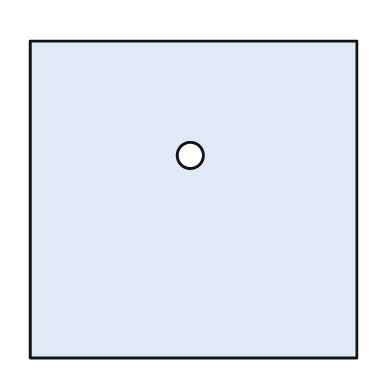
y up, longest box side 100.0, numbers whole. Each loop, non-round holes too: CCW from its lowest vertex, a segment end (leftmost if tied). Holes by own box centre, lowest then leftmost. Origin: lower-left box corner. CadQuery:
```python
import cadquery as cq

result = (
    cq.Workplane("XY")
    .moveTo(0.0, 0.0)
    .lineTo(100.0, 0.0)
    .lineTo(100.0, 97.0)
    .lineTo(0.0, 97.0)
    .close()
    .moveTo(49.0, 62.0)
    .circle(4.0)
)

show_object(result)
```